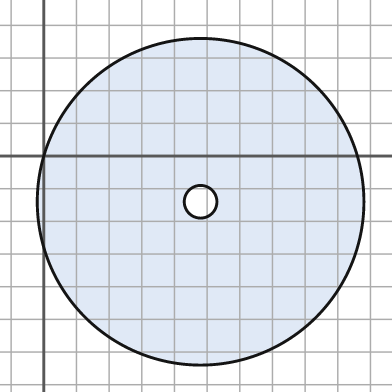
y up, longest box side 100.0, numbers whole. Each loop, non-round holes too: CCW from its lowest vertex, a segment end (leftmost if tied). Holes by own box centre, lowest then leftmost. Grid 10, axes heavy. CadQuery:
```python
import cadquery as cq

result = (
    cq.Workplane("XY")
    .moveTo(48.0, -14.0)
    .circle(50.0)
    .moveTo(48.0, -14.0)
    .circle(5.0)
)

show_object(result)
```